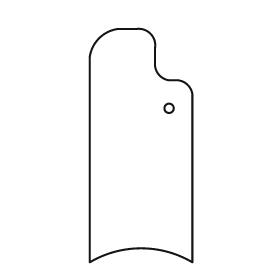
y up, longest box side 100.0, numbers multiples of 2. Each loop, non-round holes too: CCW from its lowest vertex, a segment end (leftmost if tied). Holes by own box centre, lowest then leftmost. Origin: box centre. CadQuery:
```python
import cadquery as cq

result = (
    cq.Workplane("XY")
    .moveTo(-22.0, -50.0)
    .threePointArc((0.0, -44.0), (22.0, -50.0))
    .lineTo(22.0, 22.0)
    .threePointArc((20.0, 26.0), (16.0, 28.0))
    .lineTo(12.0, 28.0)
    .threePointArc((8.0, 30.0), (6.0, 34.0))
    .lineTo(6.0, 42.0)
    .threePointArc((4.0, 48.0), (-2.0, 50.0))
    .lineTo(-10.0, 50.0)
    .threePointArc((-18.0, 46.0), (-22.0, 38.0))
    .close()
    .moveTo(12.0, 16.0)
    .circle(2.0)
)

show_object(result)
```